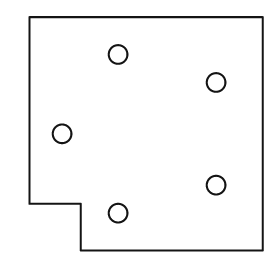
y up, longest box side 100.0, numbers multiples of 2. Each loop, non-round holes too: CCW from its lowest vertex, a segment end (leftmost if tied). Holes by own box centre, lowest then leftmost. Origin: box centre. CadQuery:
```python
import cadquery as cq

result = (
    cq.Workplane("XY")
    .moveTo(-28.0, -50.0)
    .lineTo(50.0, -50.0)
    .lineTo(50.0, 50.0)
    .lineTo(-50.0, 50.0)
    .lineTo(-50.0, -30.0)
    .lineTo(-28.0, -30.0)
    .close()
    .moveTo(-12.0, -34.0)
    .circle(4.0)
    .moveTo(30.0, -22.0)
    .circle(4.0)
    .moveTo(-36.0, 0.0)
    .circle(4.0)
    .moveTo(30.0, 22.0)
    .circle(4.0)
    .moveTo(-12.0, 34.0)
    .circle(4.0)
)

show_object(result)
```